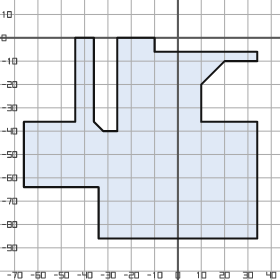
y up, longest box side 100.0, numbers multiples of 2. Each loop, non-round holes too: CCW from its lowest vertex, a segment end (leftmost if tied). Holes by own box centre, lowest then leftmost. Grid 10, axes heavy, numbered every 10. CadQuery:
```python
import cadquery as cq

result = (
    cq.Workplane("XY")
    .moveTo(-34.0, -86.0)
    .lineTo(34.0, -86.0)
    .lineTo(34.0, -36.0)
    .lineTo(10.0, -36.0)
    .lineTo(10.0, -20.0)
    .lineTo(20.0, -10.0)
    .lineTo(34.0, -10.0)
    .lineTo(34.0, -6.0)
    .lineTo(-10.0, -6.0)
    .lineTo(-10.0, 0.0)
    .lineTo(-26.0, 0.0)
    .lineTo(-26.0, -40.0)
    .lineTo(-32.0, -40.0)
    .lineTo(-36.0, -36.0)
    .lineTo(-36.0, 0.0)
    .lineTo(-44.0, 0.0)
    .lineTo(-44.0, -36.0)
    .lineTo(-66.0, -36.0)
    .lineTo(-66.0, -64.0)
    .lineTo(-34.0, -64.0)
    .close()
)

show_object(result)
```